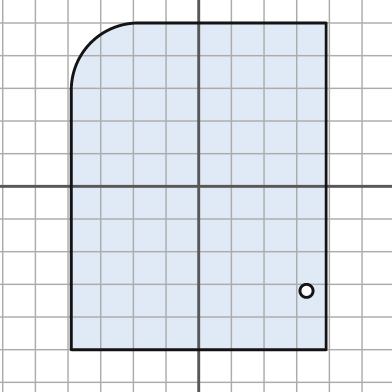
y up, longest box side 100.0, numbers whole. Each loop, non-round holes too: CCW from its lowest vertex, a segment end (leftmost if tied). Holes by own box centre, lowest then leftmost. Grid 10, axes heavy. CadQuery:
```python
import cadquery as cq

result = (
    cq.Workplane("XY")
    .moveTo(-39.0, -50.0)
    .lineTo(39.0, -50.0)
    .lineTo(39.0, 50.0)
    .lineTo(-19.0, 50.0)
    .threePointArc((-33.0, 44.0), (-39.0, 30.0))
    .close()
    .moveTo(33.0, -32.0)
    .circle(2.0)
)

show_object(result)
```